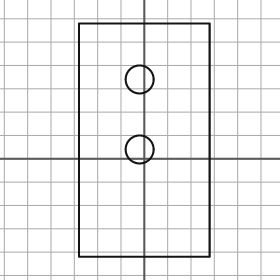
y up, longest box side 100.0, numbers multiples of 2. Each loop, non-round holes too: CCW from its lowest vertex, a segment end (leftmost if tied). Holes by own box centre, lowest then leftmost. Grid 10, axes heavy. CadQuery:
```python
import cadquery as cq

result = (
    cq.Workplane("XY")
    .moveTo(-28.0, -42.0)
    .lineTo(28.0, -42.0)
    .lineTo(28.0, 58.0)
    .lineTo(-28.0, 58.0)
    .close()
    .moveTo(-2.0, 4.0)
    .circle(6.0)
    .moveTo(-2.0, 34.0)
    .circle(6.0)
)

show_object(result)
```